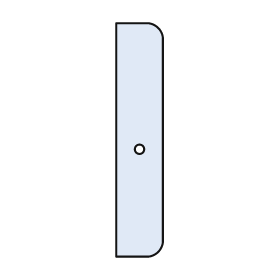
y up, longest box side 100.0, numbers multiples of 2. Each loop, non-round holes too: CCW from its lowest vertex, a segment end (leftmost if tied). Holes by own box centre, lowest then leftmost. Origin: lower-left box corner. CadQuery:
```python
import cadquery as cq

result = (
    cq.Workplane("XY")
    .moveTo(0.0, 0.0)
    .lineTo(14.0, 0.0)
    .threePointArc((18.0, 2.0), (20.0, 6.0))
    .lineTo(20.0, 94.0)
    .threePointArc((18.0, 98.0), (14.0, 100.0))
    .lineTo(0.0, 100.0)
    .close()
    .moveTo(10.0, 46.0)
    .circle(2.0)
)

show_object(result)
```